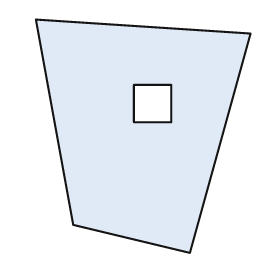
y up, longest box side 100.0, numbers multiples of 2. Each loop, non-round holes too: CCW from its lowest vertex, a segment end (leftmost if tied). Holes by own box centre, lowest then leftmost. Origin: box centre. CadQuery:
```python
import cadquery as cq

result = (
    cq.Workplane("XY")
    .moveTo(20.0, -50.0)
    .lineTo(46.0, 44.0)
    .lineTo(-46.0, 50.0)
    .lineTo(-30.0, -38.0)
    .close()
    .moveTo(-4.0, 6.0)
    .lineTo(12.0, 6.0)
    .lineTo(12.0, 22.0)
    .lineTo(-4.0, 22.0)
    .close()
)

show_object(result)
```